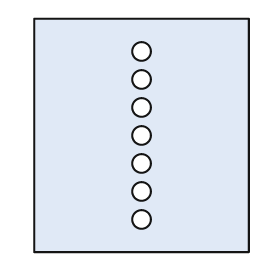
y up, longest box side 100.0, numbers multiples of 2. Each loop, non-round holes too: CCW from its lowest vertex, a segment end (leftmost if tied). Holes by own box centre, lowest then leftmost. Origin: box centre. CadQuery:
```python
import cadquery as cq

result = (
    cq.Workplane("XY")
    .moveTo(-46.0, -50.0)
    .lineTo(46.0, -50.0)
    .lineTo(46.0, 50.0)
    .lineTo(-46.0, 50.0)
    .close()
    .moveTo(0.0, -36.0)
    .circle(4.0)
    .moveTo(0.0, -24.0)
    .circle(4.0)
    .moveTo(0.0, -12.0)
    .circle(4.0)
    .moveTo(0.0, 0.0)
    .circle(4.0)
    .moveTo(0.0, 12.0)
    .circle(4.0)
    .moveTo(0.0, 24.0)
    .circle(4.0)
    .moveTo(0.0, 36.0)
    .circle(4.0)
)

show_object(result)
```